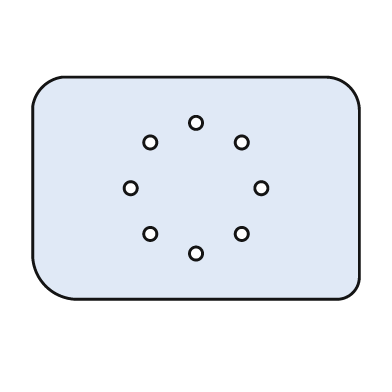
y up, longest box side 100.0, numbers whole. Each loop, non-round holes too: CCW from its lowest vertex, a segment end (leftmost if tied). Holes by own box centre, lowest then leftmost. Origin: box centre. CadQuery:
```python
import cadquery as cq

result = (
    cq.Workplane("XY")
    .moveTo(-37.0, -34.0)
    .lineTo(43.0, -34.0)
    .threePointArc((48.0, -32.0), (50.0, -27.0))
    .lineTo(50.0, 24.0)
    .threePointArc((47.0, 31.0), (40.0, 34.0))
    .lineTo(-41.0, 34.0)
    .threePointArc((-47.0, 31.0), (-50.0, 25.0))
    .lineTo(-50.0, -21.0)
    .threePointArc((-46.0, -30.0), (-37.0, -34.0))
    .close()
    .moveTo(0.0, -20.0)
    .circle(2.0)
    .moveTo(-14.0, -14.0)
    .circle(2.0)
    .moveTo(14.0, -14.0)
    .circle(2.0)
    .moveTo(-20.0, 0.0)
    .circle(2.0)
    .moveTo(20.0, 0.0)
    .circle(2.0)
    .moveTo(-14.0, 14.0)
    .circle(2.0)
    .moveTo(14.0, 14.0)
    .circle(2.0)
    .moveTo(0.0, 20.0)
    .circle(2.0)
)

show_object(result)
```